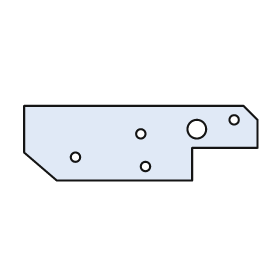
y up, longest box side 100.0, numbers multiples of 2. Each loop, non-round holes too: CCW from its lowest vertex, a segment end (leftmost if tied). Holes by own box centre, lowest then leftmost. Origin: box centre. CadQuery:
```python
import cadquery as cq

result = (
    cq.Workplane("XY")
    .moveTo(-36.0, -16.0)
    .lineTo(22.0, -16.0)
    .lineTo(22.0, -2.0)
    .lineTo(50.0, -2.0)
    .lineTo(50.0, 10.0)
    .lineTo(44.0, 16.0)
    .lineTo(-50.0, 16.0)
    .lineTo(-50.0, -4.0)
    .close()
    .moveTo(2.0, -10.0)
    .circle(2.0)
    .moveTo(-28.0, -6.0)
    .circle(2.0)
    .moveTo(0.0, 4.0)
    .circle(2.0)
    .moveTo(24.0, 6.0)
    .circle(4.0)
    .moveTo(40.0, 10.0)
    .circle(2.0)
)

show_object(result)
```